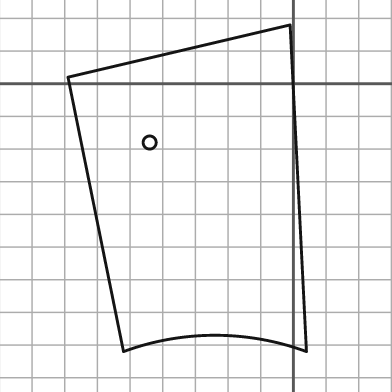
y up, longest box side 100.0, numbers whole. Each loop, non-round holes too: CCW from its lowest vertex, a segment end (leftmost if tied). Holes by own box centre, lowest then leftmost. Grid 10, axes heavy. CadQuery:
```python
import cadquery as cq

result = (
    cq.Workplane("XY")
    .moveTo(-52.0, -82.0)
    .threePointArc((-24.0, -77.0), (4.0, -82.0))
    .lineTo(-1.0, 18.0)
    .lineTo(-69.0, 2.0)
    .close()
    .moveTo(-44.0, -18.0)
    .circle(2.0)
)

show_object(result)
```